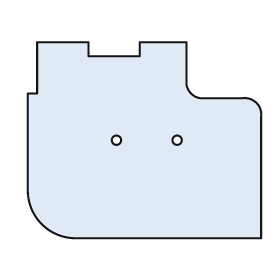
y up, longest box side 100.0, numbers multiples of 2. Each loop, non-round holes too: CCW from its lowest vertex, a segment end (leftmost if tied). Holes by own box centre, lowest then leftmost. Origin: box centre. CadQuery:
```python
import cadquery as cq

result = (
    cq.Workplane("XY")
    .moveTo(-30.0, -42.0)
    .lineTo(50.0, -42.0)
    .lineTo(50.0, 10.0)
    .threePointArc((48.0, 16.0), (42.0, 18.0))
    .lineTo(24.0, 18.0)
    .threePointArc((20.0, 20.0), (18.0, 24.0))
    .lineTo(18.0, 42.0)
    .lineTo(-2.0, 42.0)
    .lineTo(-2.0, 36.0)
    .lineTo(-24.0, 36.0)
    .lineTo(-24.0, 42.0)
    .lineTo(-46.0, 42.0)
    .lineTo(-46.0, 20.0)
    .lineTo(-50.0, 20.0)
    .lineTo(-50.0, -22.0)
    .threePointArc((-44.0, -36.0), (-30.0, -42.0))
    .close()
    .moveTo(-12.0, 0.0)
    .circle(2.0)
    .moveTo(14.0, 0.0)
    .circle(2.0)
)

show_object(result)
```